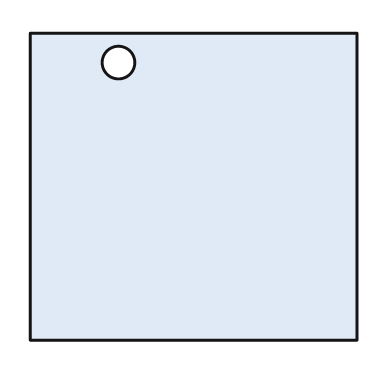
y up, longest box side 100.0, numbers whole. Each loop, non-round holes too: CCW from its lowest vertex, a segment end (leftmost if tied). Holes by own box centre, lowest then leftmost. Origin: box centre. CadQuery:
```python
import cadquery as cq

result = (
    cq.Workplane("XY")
    .moveTo(-50.0, -47.0)
    .lineTo(50.0, -47.0)
    .lineTo(50.0, 47.0)
    .lineTo(-50.0, 47.0)
    .close()
    .moveTo(-23.0, 38.0)
    .circle(5.0)
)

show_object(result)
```